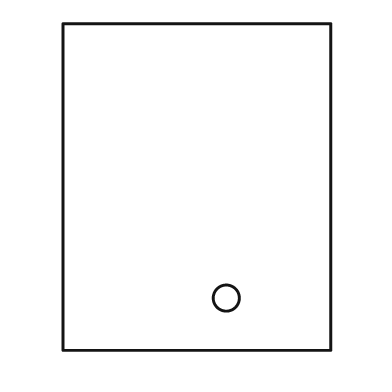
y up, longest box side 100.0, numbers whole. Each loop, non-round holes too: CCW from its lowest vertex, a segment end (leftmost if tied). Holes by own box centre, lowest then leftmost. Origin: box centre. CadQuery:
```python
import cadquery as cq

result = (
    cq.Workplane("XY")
    .moveTo(-41.0, -50.0)
    .lineTo(41.0, -50.0)
    .lineTo(41.0, 50.0)
    .lineTo(-41.0, 50.0)
    .close()
    .moveTo(9.0, -34.0)
    .circle(4.0)
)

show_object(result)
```